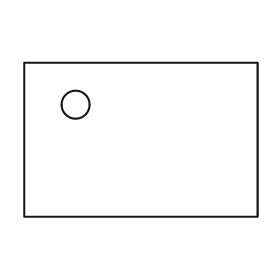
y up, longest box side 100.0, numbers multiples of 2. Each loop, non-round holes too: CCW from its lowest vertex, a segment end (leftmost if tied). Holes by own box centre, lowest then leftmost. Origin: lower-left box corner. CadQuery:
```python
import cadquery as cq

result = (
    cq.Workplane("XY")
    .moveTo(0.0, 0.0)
    .lineTo(100.0, 0.0)
    .lineTo(100.0, 66.0)
    .lineTo(0.0, 66.0)
    .close()
    .moveTo(22.0, 48.0)
    .circle(6.0)
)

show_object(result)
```